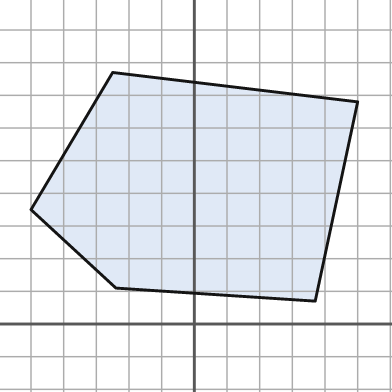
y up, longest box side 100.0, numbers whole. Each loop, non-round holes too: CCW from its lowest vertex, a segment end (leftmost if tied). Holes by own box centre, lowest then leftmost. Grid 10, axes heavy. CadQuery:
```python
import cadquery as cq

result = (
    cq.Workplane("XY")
    .moveTo(37.0, 7.0)
    .lineTo(50.0, 68.0)
    .lineTo(-25.0, 77.0)
    .lineTo(-50.0, 35.0)
    .lineTo(-24.0, 11.0)
    .close()
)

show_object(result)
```